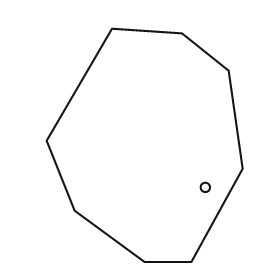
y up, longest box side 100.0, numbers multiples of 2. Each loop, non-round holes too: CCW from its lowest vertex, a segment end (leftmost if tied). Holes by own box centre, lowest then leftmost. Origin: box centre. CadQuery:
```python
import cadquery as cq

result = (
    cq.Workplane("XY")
    .moveTo(0.0, -50.0)
    .lineTo(20.0, -50.0)
    .lineTo(42.0, -10.0)
    .lineTo(36.0, 32.0)
    .lineTo(16.0, 48.0)
    .lineTo(-14.0, 50.0)
    .lineTo(-42.0, 2.0)
    .lineTo(-30.0, -28.0)
    .close()
    .moveTo(26.0, -18.0)
    .circle(2.0)
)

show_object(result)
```